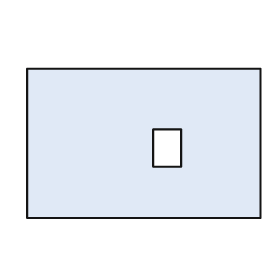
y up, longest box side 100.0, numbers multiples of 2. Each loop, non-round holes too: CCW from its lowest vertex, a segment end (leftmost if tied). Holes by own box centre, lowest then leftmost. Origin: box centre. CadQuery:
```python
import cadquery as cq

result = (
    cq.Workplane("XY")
    .moveTo(-50.0, -32.0)
    .lineTo(50.0, -32.0)
    .lineTo(50.0, 32.0)
    .lineTo(-50.0, 32.0)
    .close()
    .moveTo(4.0, -10.0)
    .lineTo(16.0, -10.0)
    .lineTo(16.0, 6.0)
    .lineTo(4.0, 6.0)
    .close()
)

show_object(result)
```